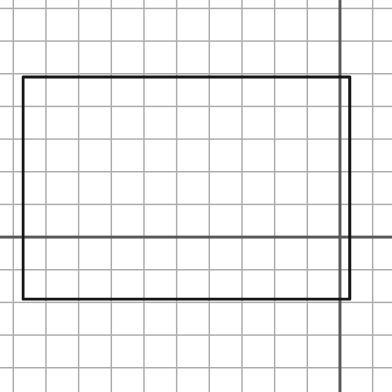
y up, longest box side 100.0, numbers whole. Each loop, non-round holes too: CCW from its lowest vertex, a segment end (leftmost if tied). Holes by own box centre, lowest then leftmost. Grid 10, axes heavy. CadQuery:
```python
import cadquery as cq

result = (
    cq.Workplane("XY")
    .moveTo(-97.0, -19.0)
    .lineTo(3.0, -19.0)
    .lineTo(3.0, 49.0)
    .lineTo(-97.0, 49.0)
    .close()
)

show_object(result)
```